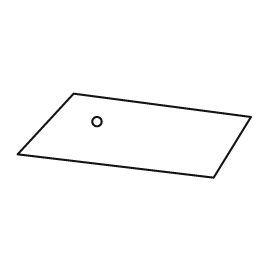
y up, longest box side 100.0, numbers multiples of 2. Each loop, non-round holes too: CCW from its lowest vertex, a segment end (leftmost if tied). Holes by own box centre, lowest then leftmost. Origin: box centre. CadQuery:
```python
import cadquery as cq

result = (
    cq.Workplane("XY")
    .moveTo(34.0, -18.0)
    .lineTo(50.0, 8.0)
    .lineTo(-26.0, 18.0)
    .lineTo(-50.0, -8.0)
    .close()
    .moveTo(-16.0, 6.0)
    .circle(2.0)
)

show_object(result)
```